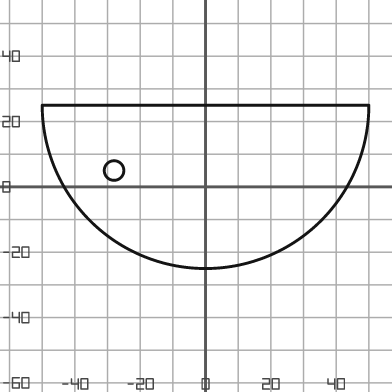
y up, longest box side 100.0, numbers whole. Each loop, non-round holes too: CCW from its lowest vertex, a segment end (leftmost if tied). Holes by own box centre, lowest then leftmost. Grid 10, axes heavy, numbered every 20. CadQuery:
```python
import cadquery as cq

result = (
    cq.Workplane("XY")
    .moveTo(-50.0, 25.0)
    .threePointArc((0.0, -25.0), (50.0, 25.0))
    .close()
    .moveTo(-28.0, 5.0)
    .circle(3.0)
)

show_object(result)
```